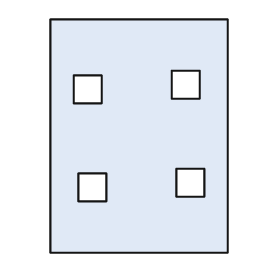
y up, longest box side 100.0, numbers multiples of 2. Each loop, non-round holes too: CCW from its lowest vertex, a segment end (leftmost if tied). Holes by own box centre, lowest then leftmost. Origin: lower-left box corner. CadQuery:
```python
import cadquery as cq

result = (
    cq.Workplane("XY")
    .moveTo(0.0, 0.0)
    .lineTo(76.0, 0.0)
    .lineTo(76.0, 100.0)
    .lineTo(0.0, 100.0)
    .close()
    .moveTo(12.0, 22.0)
    .lineTo(24.0, 22.0)
    .lineTo(24.0, 34.0)
    .lineTo(12.0, 34.0)
    .close()
    .moveTo(54.0, 24.0)
    .lineTo(66.0, 24.0)
    .lineTo(66.0, 36.0)
    .lineTo(54.0, 36.0)
    .close()
    .moveTo(10.0, 64.0)
    .lineTo(22.0, 64.0)
    .lineTo(22.0, 76.0)
    .lineTo(10.0, 76.0)
    .close()
    .moveTo(52.0, 66.0)
    .lineTo(64.0, 66.0)
    .lineTo(64.0, 78.0)
    .lineTo(52.0, 78.0)
    .close()
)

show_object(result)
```